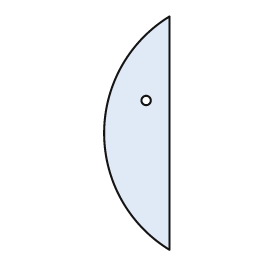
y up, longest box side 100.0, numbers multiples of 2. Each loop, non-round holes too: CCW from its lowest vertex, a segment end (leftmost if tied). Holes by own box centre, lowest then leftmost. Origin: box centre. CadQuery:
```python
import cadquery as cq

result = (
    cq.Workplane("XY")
    .moveTo(14.0, -50.0)
    .lineTo(14.0, 50.0)
    .threePointArc((-14.0, 0.0), (14.0, -50.0))
    .close()
    .moveTo(4.0, 14.0)
    .circle(2.0)
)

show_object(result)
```